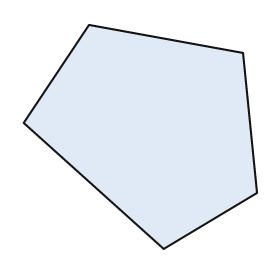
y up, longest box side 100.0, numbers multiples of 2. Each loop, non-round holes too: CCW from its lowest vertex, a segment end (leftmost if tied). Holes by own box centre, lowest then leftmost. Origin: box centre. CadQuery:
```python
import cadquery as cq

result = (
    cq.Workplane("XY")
    .moveTo(10.0, -48.0)
    .lineTo(50.0, -24.0)
    .lineTo(44.0, 36.0)
    .lineTo(-22.0, 48.0)
    .lineTo(-50.0, 6.0)
    .close()
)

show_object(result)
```